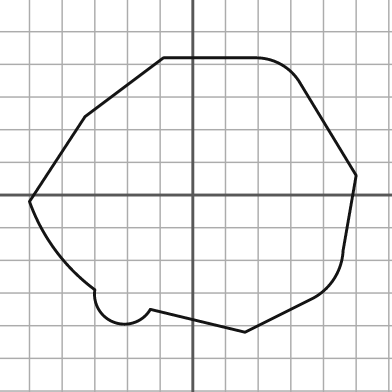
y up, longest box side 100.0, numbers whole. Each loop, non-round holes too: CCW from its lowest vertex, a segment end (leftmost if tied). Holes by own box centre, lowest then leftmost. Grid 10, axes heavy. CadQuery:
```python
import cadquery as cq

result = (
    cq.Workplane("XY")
    .moveTo(16.0, -42.0)
    .lineTo(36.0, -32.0)
    .threePointArc((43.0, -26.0), (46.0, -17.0))
    .lineTo(50.0, 6.0)
    .lineTo(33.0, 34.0)
    .threePointArc((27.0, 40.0), (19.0, 42.0))
    .lineTo(-9.0, 42.0)
    .lineTo(-33.0, 24.0)
    .lineTo(-50.0, -2.0)
    .threePointArc((-42.0, -17.0), (-30.0, -29.0))
    .threePointArc((-24.0, -39.0), (-13.0, -35.0))
    .close()
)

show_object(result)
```